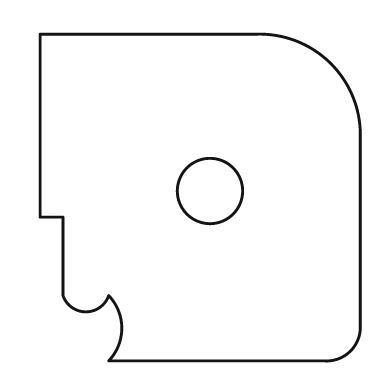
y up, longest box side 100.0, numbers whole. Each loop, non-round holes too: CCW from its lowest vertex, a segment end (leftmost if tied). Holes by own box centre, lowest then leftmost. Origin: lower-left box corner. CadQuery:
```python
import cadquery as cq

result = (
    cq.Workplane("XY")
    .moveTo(21.0, 0.0)
    .lineTo(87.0, 0.0)
    .threePointArc((95.0, 3.0), (98.0, 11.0))
    .lineTo(98.0, 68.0)
    .threePointArc((89.0, 91.0), (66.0, 100.0))
    .lineTo(0.0, 100.0)
    .lineTo(0.0, 44.0)
    .lineTo(7.0, 44.0)
    .lineTo(7.0, 20.0)
    .threePointArc((14.0, 15.0), (21.0, 20.0))
    .threePointArc((25.0, 10.0), (21.0, 0.0))
    .close()
    .moveTo(52.0, 52.0)
    .circle(10.0)
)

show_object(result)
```